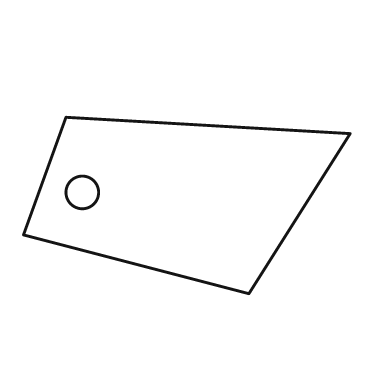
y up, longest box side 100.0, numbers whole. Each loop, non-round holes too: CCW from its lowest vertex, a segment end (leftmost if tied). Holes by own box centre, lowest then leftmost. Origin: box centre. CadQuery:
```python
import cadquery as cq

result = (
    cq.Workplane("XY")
    .moveTo(19.0, -27.0)
    .lineTo(50.0, 22.0)
    .lineTo(-37.0, 27.0)
    .lineTo(-50.0, -9.0)
    .close()
    .moveTo(-32.0, 4.0)
    .circle(5.0)
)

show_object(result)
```